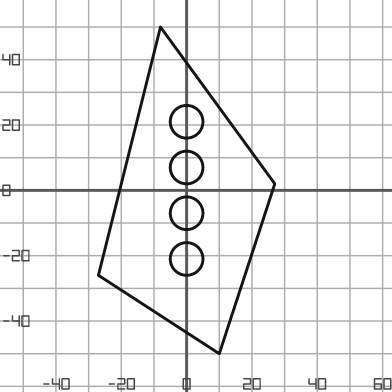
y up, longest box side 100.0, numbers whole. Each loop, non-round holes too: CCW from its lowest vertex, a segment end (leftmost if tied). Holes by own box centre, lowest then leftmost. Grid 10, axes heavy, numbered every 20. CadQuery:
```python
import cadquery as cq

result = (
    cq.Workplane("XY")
    .moveTo(10.0, -50.0)
    .lineTo(27.0, 2.0)
    .lineTo(-8.0, 50.0)
    .lineTo(-27.0, -26.0)
    .close()
    .moveTo(0.0, -21.0)
    .circle(5.0)
    .moveTo(0.0, -7.0)
    .circle(5.0)
    .moveTo(0.0, 7.0)
    .circle(5.0)
    .moveTo(0.0, 21.0)
    .circle(5.0)
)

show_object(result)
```